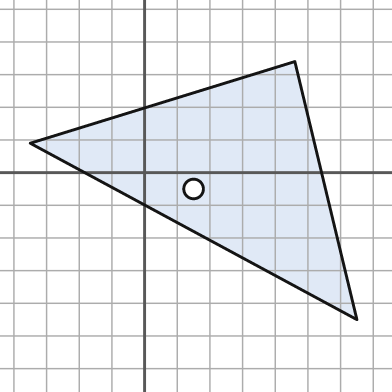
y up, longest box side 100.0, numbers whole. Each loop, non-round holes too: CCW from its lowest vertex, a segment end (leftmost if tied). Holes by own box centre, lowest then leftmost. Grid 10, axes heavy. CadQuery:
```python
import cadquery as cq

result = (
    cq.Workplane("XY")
    .moveTo(65.0, -45.0)
    .lineTo(46.0, 34.0)
    .lineTo(-35.0, 9.0)
    .close()
    .moveTo(15.0, -5.0)
    .circle(3.0)
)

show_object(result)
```